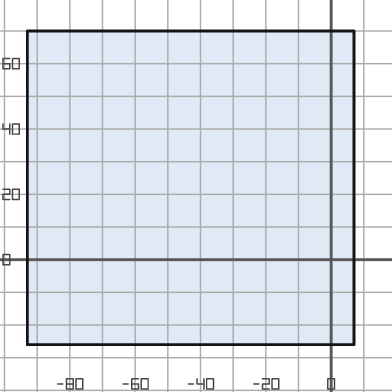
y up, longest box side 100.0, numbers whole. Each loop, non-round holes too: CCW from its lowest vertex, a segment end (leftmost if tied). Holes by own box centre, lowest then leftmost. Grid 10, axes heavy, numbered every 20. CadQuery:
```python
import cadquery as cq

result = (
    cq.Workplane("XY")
    .moveTo(-93.0, -26.0)
    .lineTo(7.0, -26.0)
    .lineTo(7.0, 70.0)
    .lineTo(-93.0, 70.0)
    .close()
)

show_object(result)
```